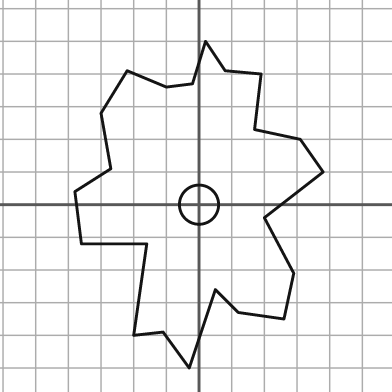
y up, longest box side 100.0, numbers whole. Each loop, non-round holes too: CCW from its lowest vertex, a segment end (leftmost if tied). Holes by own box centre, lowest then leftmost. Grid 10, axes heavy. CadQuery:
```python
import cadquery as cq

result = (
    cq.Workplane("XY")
    .moveTo(-3.0, -50.0)
    .lineTo(5.0, -26.0)
    .lineTo(12.0, -33.0)
    .lineTo(26.0, -35.0)
    .lineTo(29.0, -21.0)
    .lineTo(20.0, -4.0)
    .lineTo(38.0, 10.0)
    .lineTo(31.0, 20.0)
    .lineTo(17.0, 23.0)
    .lineTo(19.0, 40.0)
    .lineTo(8.0, 41.0)
    .lineTo(2.0, 50.0)
    .lineTo(-2.0, 37.0)
    .lineTo(-10.0, 36.0)
    .lineTo(-22.0, 41.0)
    .lineTo(-30.0, 28.0)
    .lineTo(-27.0, 11.0)
    .lineTo(-38.0, 4.0)
    .lineTo(-36.0, -12.0)
    .lineTo(-16.0, -12.0)
    .lineTo(-20.0, -40.0)
    .lineTo(-11.0, -39.0)
    .close()
    .moveTo(0.0, 0.0)
    .circle(6.0)
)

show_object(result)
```